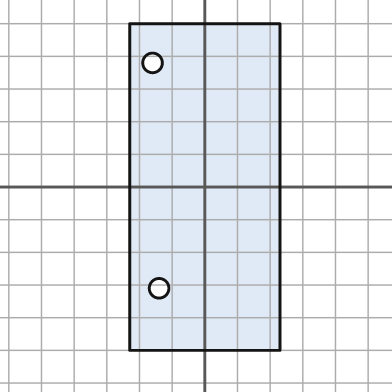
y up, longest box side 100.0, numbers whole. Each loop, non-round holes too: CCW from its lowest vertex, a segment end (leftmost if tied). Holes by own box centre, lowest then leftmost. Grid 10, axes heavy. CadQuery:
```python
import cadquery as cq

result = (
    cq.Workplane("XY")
    .moveTo(-23.0, -50.0)
    .lineTo(23.0, -50.0)
    .lineTo(23.0, 50.0)
    .lineTo(-23.0, 50.0)
    .close()
    .moveTo(-14.0, -31.0)
    .circle(3.0)
    .moveTo(-16.0, 38.0)
    .circle(3.0)
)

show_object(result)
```